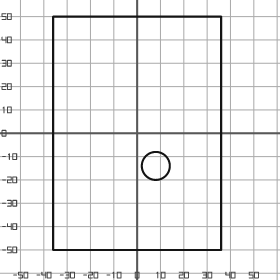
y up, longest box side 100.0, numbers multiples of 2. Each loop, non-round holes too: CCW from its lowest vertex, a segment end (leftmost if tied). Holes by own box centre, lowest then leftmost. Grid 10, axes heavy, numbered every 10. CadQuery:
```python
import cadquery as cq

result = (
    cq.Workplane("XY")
    .moveTo(-36.0, -50.0)
    .lineTo(36.0, -50.0)
    .lineTo(36.0, 50.0)
    .lineTo(-36.0, 50.0)
    .close()
    .moveTo(8.0, -14.0)
    .circle(6.0)
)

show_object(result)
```